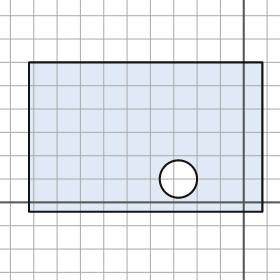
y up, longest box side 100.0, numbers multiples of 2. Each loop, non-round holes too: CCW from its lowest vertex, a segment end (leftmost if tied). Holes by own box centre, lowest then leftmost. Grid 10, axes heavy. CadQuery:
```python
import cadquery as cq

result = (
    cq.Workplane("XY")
    .moveTo(-92.0, -4.0)
    .lineTo(8.0, -4.0)
    .lineTo(8.0, 60.0)
    .lineTo(-92.0, 60.0)
    .close()
    .moveTo(-28.0, 10.0)
    .circle(8.0)
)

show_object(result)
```